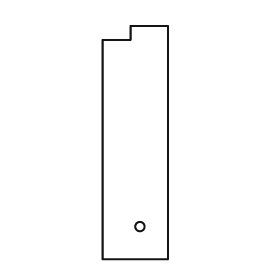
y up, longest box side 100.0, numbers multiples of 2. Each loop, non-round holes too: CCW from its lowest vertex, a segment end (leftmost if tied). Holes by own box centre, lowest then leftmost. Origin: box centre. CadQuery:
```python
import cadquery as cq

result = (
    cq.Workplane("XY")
    .moveTo(-14.0, -50.0)
    .lineTo(14.0, -50.0)
    .lineTo(14.0, 50.0)
    .lineTo(-2.0, 50.0)
    .lineTo(-2.0, 44.0)
    .lineTo(-14.0, 44.0)
    .close()
    .moveTo(2.0, -36.0)
    .circle(2.0)
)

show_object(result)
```